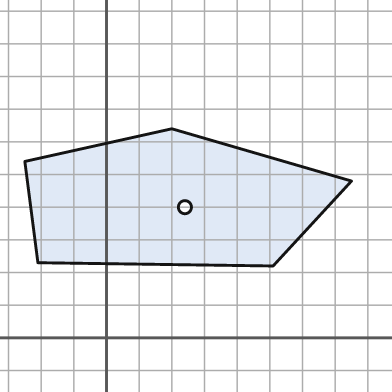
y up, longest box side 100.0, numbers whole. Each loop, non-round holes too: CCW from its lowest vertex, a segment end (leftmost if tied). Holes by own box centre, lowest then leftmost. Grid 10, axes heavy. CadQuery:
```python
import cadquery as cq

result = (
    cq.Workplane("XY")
    .moveTo(51.0, 22.0)
    .lineTo(75.0, 48.0)
    .lineTo(20.0, 64.0)
    .lineTo(-25.0, 54.0)
    .lineTo(-21.0, 23.0)
    .close()
    .moveTo(24.0, 40.0)
    .circle(2.0)
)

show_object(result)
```